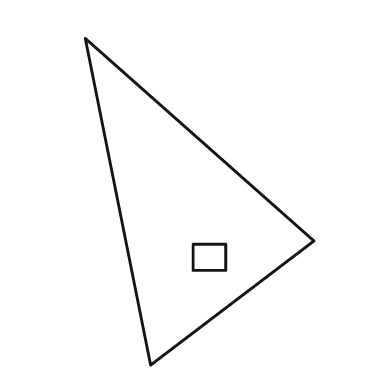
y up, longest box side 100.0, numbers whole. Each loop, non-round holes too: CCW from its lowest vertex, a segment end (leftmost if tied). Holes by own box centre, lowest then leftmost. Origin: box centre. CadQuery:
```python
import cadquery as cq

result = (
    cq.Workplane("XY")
    .moveTo(-15.0, -50.0)
    .lineTo(35.0, -12.0)
    .lineTo(-35.0, 50.0)
    .close()
    .moveTo(-2.0, -21.0)
    .lineTo(8.0, -21.0)
    .lineTo(8.0, -13.0)
    .lineTo(-2.0, -13.0)
    .close()
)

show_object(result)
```